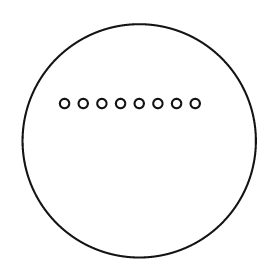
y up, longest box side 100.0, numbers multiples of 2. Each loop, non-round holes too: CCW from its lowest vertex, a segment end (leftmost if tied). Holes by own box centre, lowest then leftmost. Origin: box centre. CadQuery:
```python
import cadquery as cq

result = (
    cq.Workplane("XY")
    .moveTo(0.0, 0.0)
    .circle(50.0)
    .moveTo(-32.0, 16.0)
    .circle(2.0)
    .moveTo(-24.0, 16.0)
    .circle(2.0)
    .moveTo(-16.0, 16.0)
    .circle(2.0)
    .moveTo(-8.0, 16.0)
    .circle(2.0)
    .moveTo(0.0, 16.0)
    .circle(2.0)
    .moveTo(8.0, 16.0)
    .circle(2.0)
    .moveTo(16.0, 16.0)
    .circle(2.0)
    .moveTo(24.0, 16.0)
    .circle(2.0)
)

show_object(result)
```